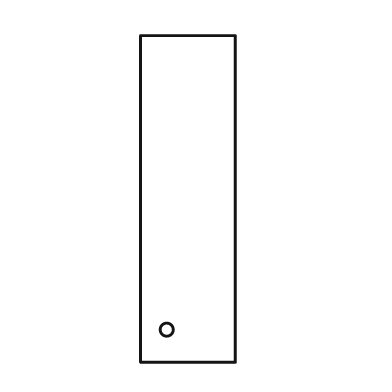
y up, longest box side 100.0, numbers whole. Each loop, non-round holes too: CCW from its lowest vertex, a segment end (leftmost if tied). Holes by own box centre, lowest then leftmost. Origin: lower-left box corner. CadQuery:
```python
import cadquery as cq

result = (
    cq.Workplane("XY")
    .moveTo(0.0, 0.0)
    .lineTo(29.0, 0.0)
    .lineTo(29.0, 100.0)
    .lineTo(0.0, 100.0)
    .close()
    .moveTo(8.0, 10.0)
    .circle(2.0)
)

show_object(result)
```